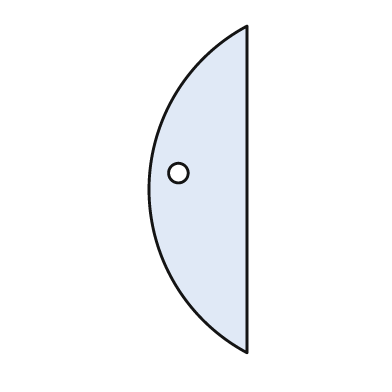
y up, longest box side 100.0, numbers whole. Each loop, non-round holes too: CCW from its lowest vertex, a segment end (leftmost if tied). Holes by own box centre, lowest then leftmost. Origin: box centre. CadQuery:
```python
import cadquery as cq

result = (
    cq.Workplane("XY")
    .moveTo(15.0, -50.0)
    .lineTo(15.0, 50.0)
    .threePointArc((-15.0, 0.0), (15.0, -50.0))
    .close()
    .moveTo(-6.0, 5.0)
    .circle(3.0)
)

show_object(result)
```